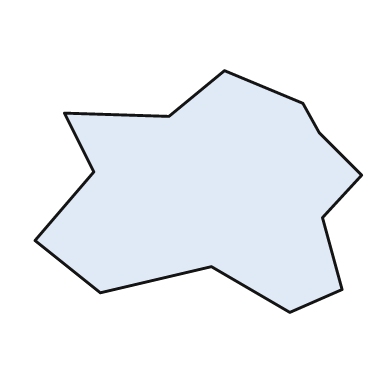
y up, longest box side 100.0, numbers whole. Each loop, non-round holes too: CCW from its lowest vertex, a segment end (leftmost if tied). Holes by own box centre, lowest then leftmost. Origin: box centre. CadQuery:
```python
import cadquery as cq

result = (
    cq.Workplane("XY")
    .moveTo(28.0, -37.0)
    .lineTo(44.0, -30.0)
    .lineTo(38.0, -8.0)
    .lineTo(50.0, 5.0)
    .lineTo(37.0, 18.0)
    .lineTo(32.0, 27.0)
    .lineTo(8.0, 37.0)
    .lineTo(-9.0, 23.0)
    .lineTo(-41.0, 24.0)
    .lineTo(-32.0, 6.0)
    .lineTo(-50.0, -15.0)
    .lineTo(-30.0, -31.0)
    .lineTo(4.0, -23.0)
    .close()
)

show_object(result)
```